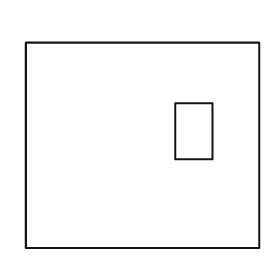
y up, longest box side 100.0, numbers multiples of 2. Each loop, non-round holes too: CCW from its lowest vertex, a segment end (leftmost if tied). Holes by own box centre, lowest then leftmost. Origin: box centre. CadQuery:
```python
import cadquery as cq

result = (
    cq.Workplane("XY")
    .moveTo(-50.0, -44.0)
    .lineTo(50.0, -44.0)
    .lineTo(50.0, 44.0)
    .lineTo(-50.0, 44.0)
    .close()
    .moveTo(14.0, -6.0)
    .lineTo(30.0, -6.0)
    .lineTo(30.0, 18.0)
    .lineTo(14.0, 18.0)
    .close()
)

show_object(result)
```